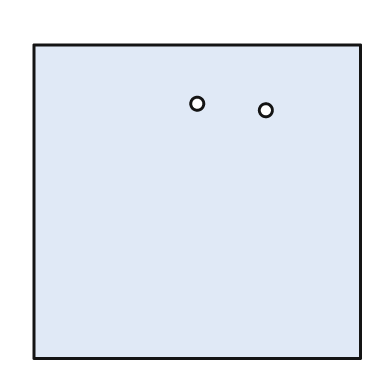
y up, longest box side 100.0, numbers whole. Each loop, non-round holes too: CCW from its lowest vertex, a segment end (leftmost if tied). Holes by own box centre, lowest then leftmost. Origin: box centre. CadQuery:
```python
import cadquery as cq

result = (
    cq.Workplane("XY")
    .moveTo(-50.0, -48.0)
    .lineTo(50.0, -48.0)
    .lineTo(50.0, 48.0)
    .lineTo(-50.0, 48.0)
    .close()
    .moveTo(21.0, 28.0)
    .circle(2.0)
    .moveTo(0.0, 30.0)
    .circle(2.0)
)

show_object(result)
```